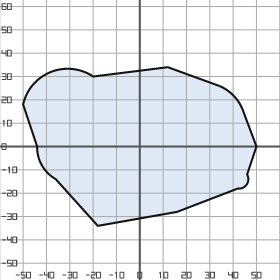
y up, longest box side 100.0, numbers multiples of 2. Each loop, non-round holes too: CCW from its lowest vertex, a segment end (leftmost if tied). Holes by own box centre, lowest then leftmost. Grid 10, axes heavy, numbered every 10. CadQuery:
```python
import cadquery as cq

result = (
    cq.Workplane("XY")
    .moveTo(-18.0, -34.0)
    .lineTo(16.0, -28.0)
    .lineTo(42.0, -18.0)
    .threePointArc((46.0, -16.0), (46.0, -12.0))
    .lineTo(50.0, 0.0)
    .lineTo(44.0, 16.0)
    .threePointArc((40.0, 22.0), (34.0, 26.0))
    .lineTo(12.0, 34.0)
    .lineTo(-20.0, 30.0)
    .threePointArc((-38.0, 32.0), (-50.0, 18.0))
    .lineTo(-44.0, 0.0)
    .threePointArc((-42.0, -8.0), (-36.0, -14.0))
    .close()
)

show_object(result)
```